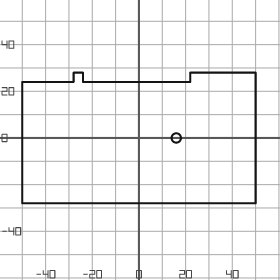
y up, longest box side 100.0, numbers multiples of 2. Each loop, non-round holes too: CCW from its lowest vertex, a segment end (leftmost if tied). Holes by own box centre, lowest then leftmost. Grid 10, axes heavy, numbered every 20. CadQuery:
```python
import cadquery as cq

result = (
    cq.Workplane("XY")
    .moveTo(-50.0, -28.0)
    .lineTo(50.0, -28.0)
    .lineTo(50.0, 28.0)
    .lineTo(22.0, 28.0)
    .lineTo(22.0, 24.0)
    .lineTo(-24.0, 24.0)
    .lineTo(-24.0, 28.0)
    .lineTo(-28.0, 28.0)
    .lineTo(-28.0, 24.0)
    .lineTo(-50.0, 24.0)
    .close()
    .moveTo(16.0, 0.0)
    .circle(2.0)
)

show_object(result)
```